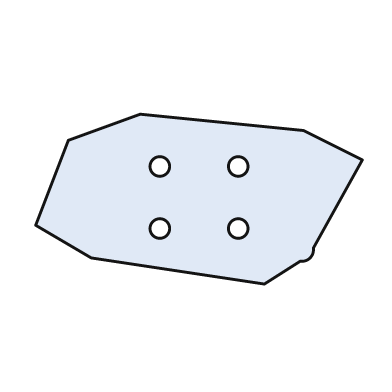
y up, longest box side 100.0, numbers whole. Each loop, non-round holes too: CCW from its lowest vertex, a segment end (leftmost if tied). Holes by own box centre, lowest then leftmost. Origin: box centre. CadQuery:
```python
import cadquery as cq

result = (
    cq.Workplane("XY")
    .moveTo(20.0, -26.0)
    .lineTo(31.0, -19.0)
    .threePointArc((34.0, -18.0), (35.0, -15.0))
    .lineTo(50.0, 12.0)
    .lineTo(32.0, 21.0)
    .lineTo(-18.0, 26.0)
    .lineTo(-40.0, 18.0)
    .lineTo(-50.0, -8.0)
    .lineTo(-33.0, -18.0)
    .close()
    .moveTo(-12.0, -9.0)
    .circle(3.0)
    .moveTo(12.0, -9.0)
    .circle(3.0)
    .moveTo(-12.0, 10.0)
    .circle(3.0)
    .moveTo(12.0, 10.0)
    .circle(3.0)
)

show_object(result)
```